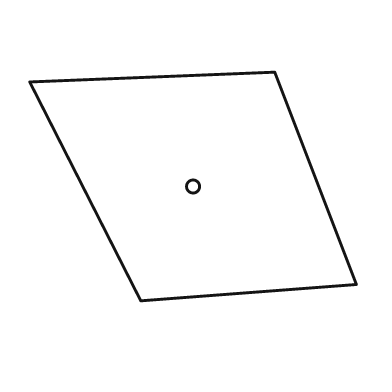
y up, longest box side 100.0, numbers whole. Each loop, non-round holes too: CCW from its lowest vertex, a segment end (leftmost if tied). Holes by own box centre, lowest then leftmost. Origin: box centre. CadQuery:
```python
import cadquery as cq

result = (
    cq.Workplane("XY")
    .moveTo(-16.0, -35.0)
    .lineTo(50.0, -30.0)
    .lineTo(25.0, 35.0)
    .lineTo(-50.0, 32.0)
    .close()
    .moveTo(0.0, 0.0)
    .circle(2.0)
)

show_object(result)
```